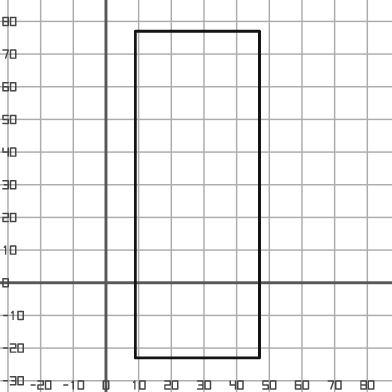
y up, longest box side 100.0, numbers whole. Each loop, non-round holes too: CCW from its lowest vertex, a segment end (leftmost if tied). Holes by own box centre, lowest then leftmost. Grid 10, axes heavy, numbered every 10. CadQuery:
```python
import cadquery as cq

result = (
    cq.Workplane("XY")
    .moveTo(9.0, -23.0)
    .lineTo(47.0, -23.0)
    .lineTo(47.0, 77.0)
    .lineTo(9.0, 77.0)
    .close()
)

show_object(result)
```